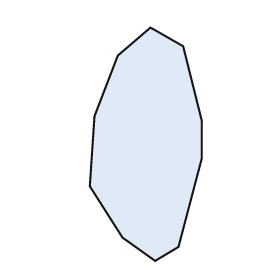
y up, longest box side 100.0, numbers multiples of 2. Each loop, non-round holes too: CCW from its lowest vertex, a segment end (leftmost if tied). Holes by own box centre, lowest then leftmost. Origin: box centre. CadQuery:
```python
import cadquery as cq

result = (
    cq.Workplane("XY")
    .moveTo(4.0, -50.0)
    .lineTo(14.0, -44.0)
    .lineTo(24.0, -6.0)
    .lineTo(24.0, 10.0)
    .lineTo(16.0, 42.0)
    .lineTo(2.0, 50.0)
    .lineTo(-12.0, 38.0)
    .lineTo(-22.0, 12.0)
    .lineTo(-24.0, -18.0)
    .lineTo(-10.0, -40.0)
    .close()
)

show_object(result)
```